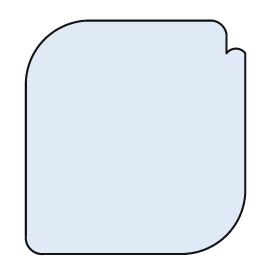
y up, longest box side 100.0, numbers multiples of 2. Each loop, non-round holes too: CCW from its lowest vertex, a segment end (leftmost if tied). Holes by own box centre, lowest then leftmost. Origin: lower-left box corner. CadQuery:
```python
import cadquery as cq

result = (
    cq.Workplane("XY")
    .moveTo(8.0, 0.0)
    .lineTo(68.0, 0.0)
    .threePointArc((86.0, 8.0), (94.0, 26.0))
    .lineTo(94.0, 86.0)
    .threePointArc((90.0, 88.0), (86.0, 86.0))
    .lineTo(86.0, 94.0)
    .threePointArc((84.0, 98.0), (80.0, 100.0))
    .lineTo(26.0, 100.0)
    .threePointArc((8.0, 92.0), (0.0, 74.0))
    .lineTo(0.0, 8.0)
    .threePointArc((2.0, 2.0), (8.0, 0.0))
    .close()
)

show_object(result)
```